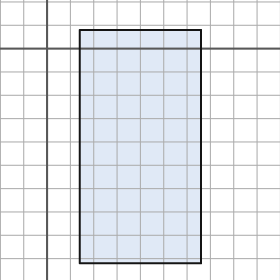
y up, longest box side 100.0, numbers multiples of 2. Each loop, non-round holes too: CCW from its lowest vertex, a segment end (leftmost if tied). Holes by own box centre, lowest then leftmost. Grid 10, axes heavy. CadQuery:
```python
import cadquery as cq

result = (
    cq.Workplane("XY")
    .moveTo(14.0, -92.0)
    .lineTo(66.0, -92.0)
    .lineTo(66.0, 8.0)
    .lineTo(14.0, 8.0)
    .close()
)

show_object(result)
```